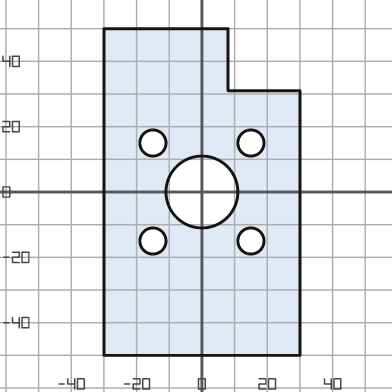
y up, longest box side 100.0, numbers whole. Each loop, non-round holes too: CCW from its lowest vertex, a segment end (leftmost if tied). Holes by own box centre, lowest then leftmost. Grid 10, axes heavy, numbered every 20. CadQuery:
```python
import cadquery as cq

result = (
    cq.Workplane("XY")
    .moveTo(-30.0, -50.0)
    .lineTo(30.0, -50.0)
    .lineTo(30.0, 31.0)
    .lineTo(8.0, 31.0)
    .lineTo(8.0, 50.0)
    .lineTo(-30.0, 50.0)
    .close()
    .moveTo(-15.0, -15.0)
    .circle(4.0)
    .moveTo(15.0, -15.0)
    .circle(4.0)
    .moveTo(0.0, 0.0)
    .circle(11.0)
    .moveTo(-15.0, 15.0)
    .circle(4.0)
    .moveTo(15.0, 15.0)
    .circle(4.0)
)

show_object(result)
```